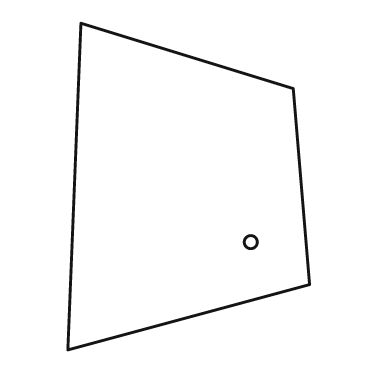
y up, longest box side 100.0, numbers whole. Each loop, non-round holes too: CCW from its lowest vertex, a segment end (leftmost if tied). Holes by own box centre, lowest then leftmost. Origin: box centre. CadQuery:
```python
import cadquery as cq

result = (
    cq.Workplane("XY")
    .moveTo(-37.0, -50.0)
    .lineTo(37.0, -30.0)
    .lineTo(32.0, 30.0)
    .lineTo(-33.0, 50.0)
    .close()
    .moveTo(19.0, -17.0)
    .circle(2.0)
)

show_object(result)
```